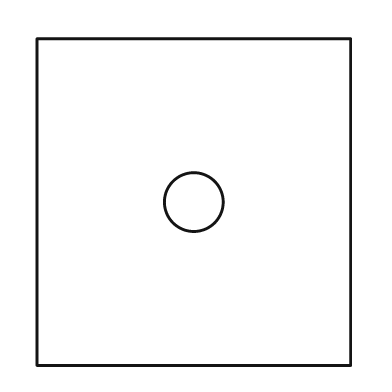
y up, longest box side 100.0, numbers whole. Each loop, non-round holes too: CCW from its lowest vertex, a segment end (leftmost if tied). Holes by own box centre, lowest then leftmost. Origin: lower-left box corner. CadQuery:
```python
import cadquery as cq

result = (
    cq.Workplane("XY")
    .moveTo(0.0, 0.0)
    .lineTo(96.0, 0.0)
    .lineTo(96.0, 100.0)
    .lineTo(0.0, 100.0)
    .close()
    .moveTo(48.0, 50.0)
    .circle(9.0)
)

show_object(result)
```